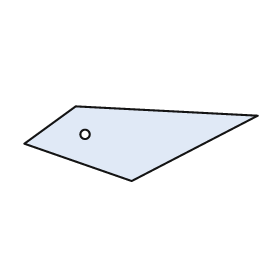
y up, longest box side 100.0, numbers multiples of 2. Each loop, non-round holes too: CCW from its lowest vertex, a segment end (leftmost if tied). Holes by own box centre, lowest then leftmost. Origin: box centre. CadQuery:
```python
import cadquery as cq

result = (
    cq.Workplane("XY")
    .moveTo(-4.0, -16.0)
    .lineTo(50.0, 12.0)
    .lineTo(-28.0, 16.0)
    .lineTo(-50.0, 0.0)
    .close()
    .moveTo(-24.0, 4.0)
    .circle(2.0)
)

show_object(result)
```